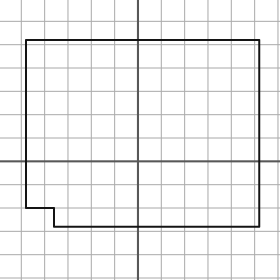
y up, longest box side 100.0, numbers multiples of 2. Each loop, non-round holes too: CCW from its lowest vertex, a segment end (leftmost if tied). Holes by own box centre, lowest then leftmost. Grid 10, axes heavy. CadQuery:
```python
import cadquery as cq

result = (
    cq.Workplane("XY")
    .moveTo(-36.0, -28.0)
    .lineTo(52.0, -28.0)
    .lineTo(52.0, 52.0)
    .lineTo(-48.0, 52.0)
    .lineTo(-48.0, -20.0)
    .lineTo(-36.0, -20.0)
    .close()
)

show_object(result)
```